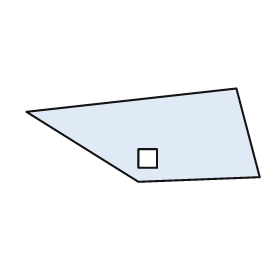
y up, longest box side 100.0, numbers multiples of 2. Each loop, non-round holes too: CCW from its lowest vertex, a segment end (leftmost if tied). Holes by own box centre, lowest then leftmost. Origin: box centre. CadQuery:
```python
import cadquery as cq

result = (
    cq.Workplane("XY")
    .moveTo(-2.0, -20.0)
    .lineTo(50.0, -18.0)
    .lineTo(40.0, 20.0)
    .lineTo(-50.0, 10.0)
    .close()
    .moveTo(-2.0, -14.0)
    .lineTo(6.0, -14.0)
    .lineTo(6.0, -6.0)
    .lineTo(-2.0, -6.0)
    .close()
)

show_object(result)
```